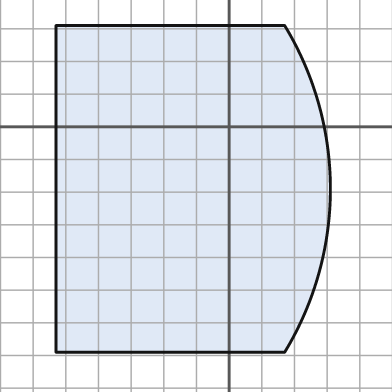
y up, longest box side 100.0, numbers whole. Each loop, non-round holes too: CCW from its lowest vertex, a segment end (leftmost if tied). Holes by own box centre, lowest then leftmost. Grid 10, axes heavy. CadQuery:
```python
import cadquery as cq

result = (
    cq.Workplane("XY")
    .moveTo(-53.0, -69.0)
    .lineTo(17.0, -69.0)
    .threePointArc((31.0, -19.0), (17.0, 31.0))
    .lineTo(-53.0, 31.0)
    .close()
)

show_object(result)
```